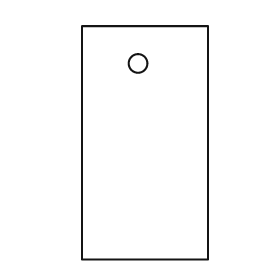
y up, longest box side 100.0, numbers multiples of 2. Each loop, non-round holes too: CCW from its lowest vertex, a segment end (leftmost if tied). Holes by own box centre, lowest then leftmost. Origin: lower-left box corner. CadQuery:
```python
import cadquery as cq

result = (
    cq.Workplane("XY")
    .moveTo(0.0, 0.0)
    .lineTo(54.0, 0.0)
    .lineTo(54.0, 100.0)
    .lineTo(0.0, 100.0)
    .close()
    .moveTo(24.0, 84.0)
    .circle(4.0)
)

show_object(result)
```